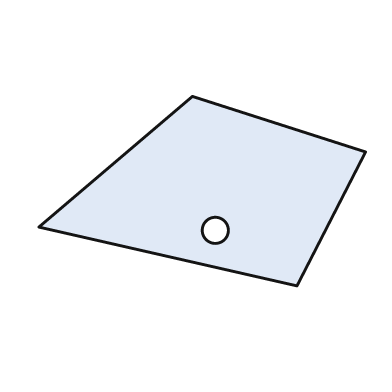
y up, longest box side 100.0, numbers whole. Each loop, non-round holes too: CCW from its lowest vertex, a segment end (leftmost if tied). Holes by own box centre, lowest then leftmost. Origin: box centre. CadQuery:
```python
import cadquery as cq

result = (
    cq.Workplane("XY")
    .moveTo(29.0, -29.0)
    .lineTo(50.0, 12.0)
    .lineTo(-3.0, 29.0)
    .lineTo(-50.0, -11.0)
    .close()
    .moveTo(4.0, -12.0)
    .circle(4.0)
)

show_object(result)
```